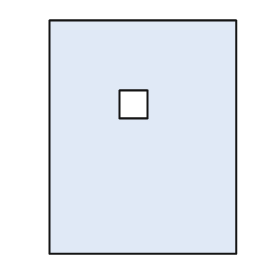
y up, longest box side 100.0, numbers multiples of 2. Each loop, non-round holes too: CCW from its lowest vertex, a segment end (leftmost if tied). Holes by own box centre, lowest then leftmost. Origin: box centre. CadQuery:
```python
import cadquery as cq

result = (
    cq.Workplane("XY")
    .moveTo(-40.0, -50.0)
    .lineTo(40.0, -50.0)
    .lineTo(40.0, 50.0)
    .lineTo(-40.0, 50.0)
    .close()
    .moveTo(-10.0, 8.0)
    .lineTo(2.0, 8.0)
    .lineTo(2.0, 20.0)
    .lineTo(-10.0, 20.0)
    .close()
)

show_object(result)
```